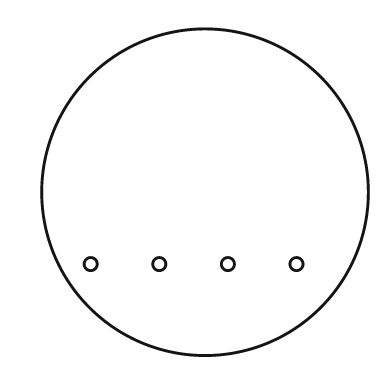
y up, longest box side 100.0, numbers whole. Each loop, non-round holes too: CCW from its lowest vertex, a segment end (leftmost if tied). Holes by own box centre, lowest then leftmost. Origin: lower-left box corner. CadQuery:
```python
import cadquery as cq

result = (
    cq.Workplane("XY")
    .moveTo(50.0, 50.0)
    .circle(50.0)
    .moveTo(15.0, 28.0)
    .circle(2.0)
    .moveTo(36.0, 28.0)
    .circle(2.0)
    .moveTo(57.0, 28.0)
    .circle(2.0)
    .moveTo(78.0, 28.0)
    .circle(2.0)
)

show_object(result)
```